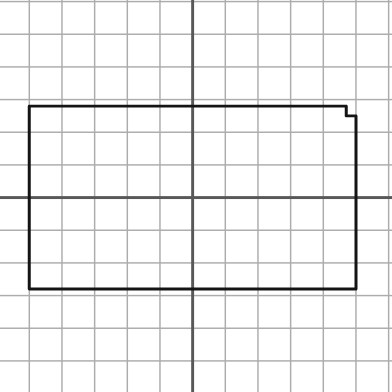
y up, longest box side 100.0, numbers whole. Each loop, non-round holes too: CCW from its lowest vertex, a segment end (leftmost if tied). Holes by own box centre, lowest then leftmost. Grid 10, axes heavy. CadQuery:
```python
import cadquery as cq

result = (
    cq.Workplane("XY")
    .moveTo(-50.0, -28.0)
    .lineTo(50.0, -28.0)
    .lineTo(50.0, 25.0)
    .lineTo(47.0, 25.0)
    .lineTo(47.0, 28.0)
    .lineTo(-50.0, 28.0)
    .close()
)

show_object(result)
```